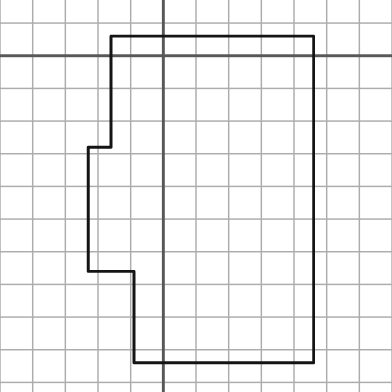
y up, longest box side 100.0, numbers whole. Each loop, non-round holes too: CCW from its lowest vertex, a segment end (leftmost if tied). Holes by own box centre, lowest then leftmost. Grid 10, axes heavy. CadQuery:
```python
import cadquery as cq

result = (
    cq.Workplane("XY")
    .moveTo(-9.0, -94.0)
    .lineTo(46.0, -94.0)
    .lineTo(46.0, 6.0)
    .lineTo(-16.0, 6.0)
    .lineTo(-16.0, -28.0)
    .lineTo(-23.0, -28.0)
    .lineTo(-23.0, -66.0)
    .lineTo(-9.0, -66.0)
    .close()
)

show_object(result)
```